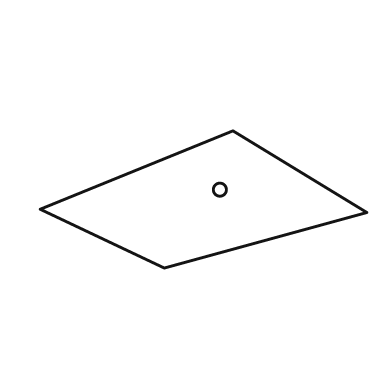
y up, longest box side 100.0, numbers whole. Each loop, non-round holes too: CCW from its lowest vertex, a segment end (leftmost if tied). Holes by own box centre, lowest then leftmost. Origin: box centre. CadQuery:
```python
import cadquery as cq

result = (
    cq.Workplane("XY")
    .moveTo(-12.0, -21.0)
    .lineTo(50.0, -4.0)
    .lineTo(9.0, 21.0)
    .lineTo(-50.0, -3.0)
    .close()
    .moveTo(5.0, 3.0)
    .circle(2.0)
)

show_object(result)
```